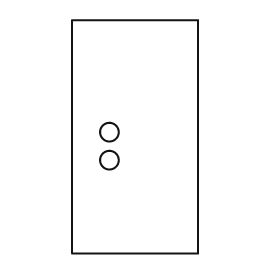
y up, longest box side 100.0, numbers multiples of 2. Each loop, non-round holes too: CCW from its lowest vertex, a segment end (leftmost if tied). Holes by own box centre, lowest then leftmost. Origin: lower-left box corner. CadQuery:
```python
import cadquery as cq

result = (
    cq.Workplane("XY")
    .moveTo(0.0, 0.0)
    .lineTo(54.0, 0.0)
    .lineTo(54.0, 100.0)
    .lineTo(0.0, 100.0)
    .close()
    .moveTo(16.0, 40.0)
    .circle(4.0)
    .moveTo(16.0, 52.0)
    .circle(4.0)
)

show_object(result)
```